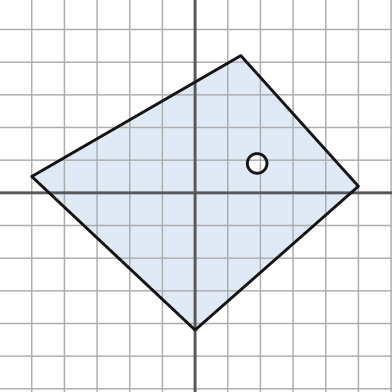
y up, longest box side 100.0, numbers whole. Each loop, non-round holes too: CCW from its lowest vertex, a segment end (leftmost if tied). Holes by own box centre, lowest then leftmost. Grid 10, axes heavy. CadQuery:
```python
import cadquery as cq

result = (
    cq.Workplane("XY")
    .moveTo(0.0, -42.0)
    .lineTo(50.0, 2.0)
    .lineTo(14.0, 42.0)
    .lineTo(-50.0, 5.0)
    .close()
    .moveTo(19.0, 9.0)
    .circle(3.0)
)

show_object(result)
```